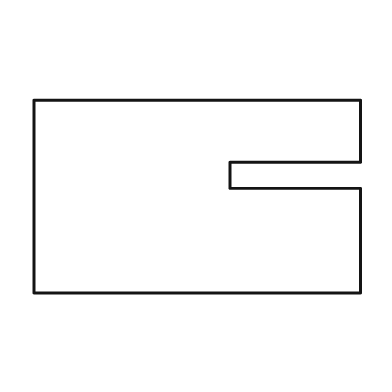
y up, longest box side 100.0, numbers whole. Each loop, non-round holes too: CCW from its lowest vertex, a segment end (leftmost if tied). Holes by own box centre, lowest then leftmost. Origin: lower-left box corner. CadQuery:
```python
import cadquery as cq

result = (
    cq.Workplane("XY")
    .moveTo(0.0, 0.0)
    .lineTo(100.0, 0.0)
    .lineTo(100.0, 32.0)
    .lineTo(60.0, 32.0)
    .lineTo(60.0, 40.0)
    .lineTo(100.0, 40.0)
    .lineTo(100.0, 59.0)
    .lineTo(0.0, 59.0)
    .close()
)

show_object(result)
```